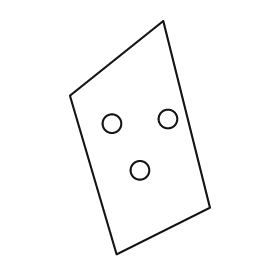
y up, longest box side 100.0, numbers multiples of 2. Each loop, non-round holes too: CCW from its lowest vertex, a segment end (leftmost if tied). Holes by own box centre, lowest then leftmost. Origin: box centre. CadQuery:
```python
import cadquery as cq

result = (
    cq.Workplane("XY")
    .moveTo(-10.0, -50.0)
    .lineTo(30.0, -30.0)
    .lineTo(10.0, 50.0)
    .lineTo(-30.0, 18.0)
    .close()
    .moveTo(0.0, -14.0)
    .circle(4.0)
    .moveTo(-12.0, 6.0)
    .circle(4.0)
    .moveTo(12.0, 8.0)
    .circle(4.0)
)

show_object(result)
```